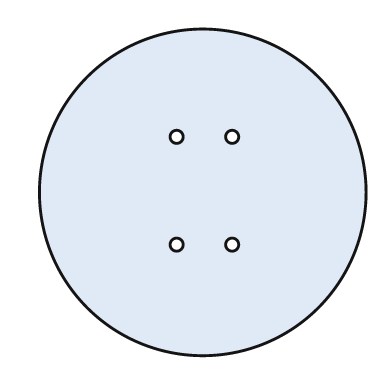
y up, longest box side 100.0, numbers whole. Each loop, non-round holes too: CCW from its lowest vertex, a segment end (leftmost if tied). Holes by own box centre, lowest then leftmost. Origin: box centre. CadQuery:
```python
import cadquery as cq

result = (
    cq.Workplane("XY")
    .moveTo(0.0, 0.0)
    .circle(50.0)
    .moveTo(-8.0, -16.0)
    .circle(2.0)
    .moveTo(9.0, -16.0)
    .circle(2.0)
    .moveTo(-8.0, 17.0)
    .circle(2.0)
    .moveTo(9.0, 17.0)
    .circle(2.0)
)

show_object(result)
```